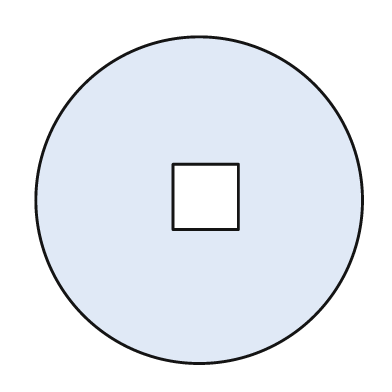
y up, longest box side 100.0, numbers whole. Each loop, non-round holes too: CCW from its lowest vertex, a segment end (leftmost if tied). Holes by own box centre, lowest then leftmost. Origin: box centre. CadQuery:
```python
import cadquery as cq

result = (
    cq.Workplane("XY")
    .moveTo(0.0, 0.0)
    .circle(50.0)
    .moveTo(-8.0, -9.0)
    .lineTo(12.0, -9.0)
    .lineTo(12.0, 11.0)
    .lineTo(-8.0, 11.0)
    .close()
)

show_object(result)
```